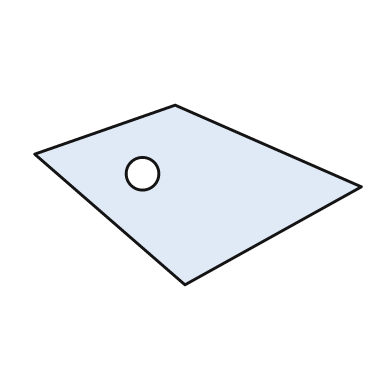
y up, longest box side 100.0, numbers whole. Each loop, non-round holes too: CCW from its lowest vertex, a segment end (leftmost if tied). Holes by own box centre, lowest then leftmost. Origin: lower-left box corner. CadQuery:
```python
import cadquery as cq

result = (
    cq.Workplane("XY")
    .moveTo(46.0, 0.0)
    .lineTo(100.0, 30.0)
    .lineTo(43.0, 55.0)
    .lineTo(0.0, 40.0)
    .close()
    .moveTo(33.0, 34.0)
    .circle(5.0)
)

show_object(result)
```